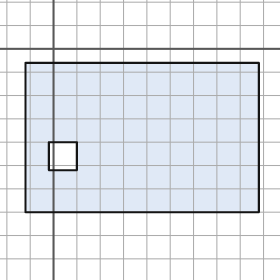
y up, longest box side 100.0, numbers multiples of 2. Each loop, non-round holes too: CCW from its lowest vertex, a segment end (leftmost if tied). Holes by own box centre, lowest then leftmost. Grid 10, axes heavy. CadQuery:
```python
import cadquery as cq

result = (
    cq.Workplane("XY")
    .moveTo(-12.0, -70.0)
    .lineTo(88.0, -70.0)
    .lineTo(88.0, -6.0)
    .lineTo(-12.0, -6.0)
    .close()
    .moveTo(-2.0, -52.0)
    .lineTo(10.0, -52.0)
    .lineTo(10.0, -40.0)
    .lineTo(-2.0, -40.0)
    .close()
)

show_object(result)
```